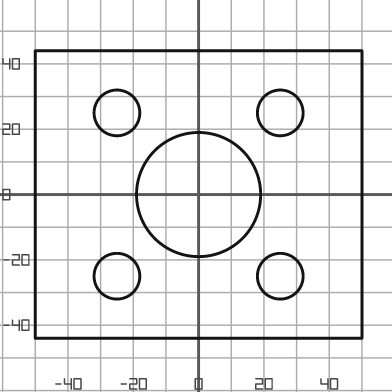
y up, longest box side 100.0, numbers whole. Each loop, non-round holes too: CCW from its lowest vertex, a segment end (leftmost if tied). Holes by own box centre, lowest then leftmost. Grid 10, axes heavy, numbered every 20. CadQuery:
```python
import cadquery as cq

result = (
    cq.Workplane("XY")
    .moveTo(-50.0, -44.0)
    .lineTo(50.0, -44.0)
    .lineTo(50.0, 44.0)
    .lineTo(-50.0, 44.0)
    .close()
    .moveTo(-25.0, -25.0)
    .circle(7.0)
    .moveTo(25.0, -25.0)
    .circle(7.0)
    .moveTo(0.0, 0.0)
    .circle(19.0)
    .moveTo(-25.0, 25.0)
    .circle(7.0)
    .moveTo(25.0, 25.0)
    .circle(7.0)
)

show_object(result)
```